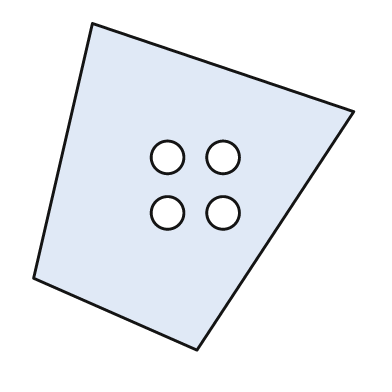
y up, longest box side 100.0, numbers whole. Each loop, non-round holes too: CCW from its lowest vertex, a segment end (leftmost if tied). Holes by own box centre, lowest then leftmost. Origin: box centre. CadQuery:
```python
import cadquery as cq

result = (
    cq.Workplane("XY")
    .moveTo(1.0, -50.0)
    .lineTo(49.0, 23.0)
    .lineTo(-31.0, 50.0)
    .lineTo(-49.0, -28.0)
    .close()
    .moveTo(-8.0, -8.0)
    .circle(5.0)
    .moveTo(9.0, -8.0)
    .circle(5.0)
    .moveTo(-8.0, 9.0)
    .circle(5.0)
    .moveTo(9.0, 9.0)
    .circle(5.0)
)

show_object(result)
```